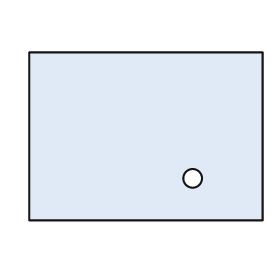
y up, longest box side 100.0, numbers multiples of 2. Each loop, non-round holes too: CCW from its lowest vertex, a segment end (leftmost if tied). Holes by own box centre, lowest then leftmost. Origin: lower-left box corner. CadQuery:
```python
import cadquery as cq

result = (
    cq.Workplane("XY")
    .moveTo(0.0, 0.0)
    .lineTo(100.0, 0.0)
    .lineTo(100.0, 72.0)
    .lineTo(0.0, 72.0)
    .close()
    .moveTo(70.0, 18.0)
    .circle(4.0)
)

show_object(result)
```